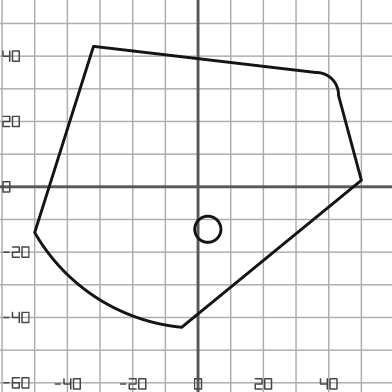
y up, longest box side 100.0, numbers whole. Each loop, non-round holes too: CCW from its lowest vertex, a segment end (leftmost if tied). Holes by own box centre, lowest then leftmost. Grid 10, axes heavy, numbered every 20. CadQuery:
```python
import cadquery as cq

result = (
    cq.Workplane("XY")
    .moveTo(-5.0, -43.0)
    .lineTo(50.0, 2.0)
    .lineTo(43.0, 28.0)
    .threePointArc((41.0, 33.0), (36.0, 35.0))
    .lineTo(-32.0, 43.0)
    .lineTo(-50.0, -14.0)
    .threePointArc((-31.0, -34.0), (-5.0, -43.0))
    .close()
    .moveTo(3.0, -13.0)
    .circle(4.0)
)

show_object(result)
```